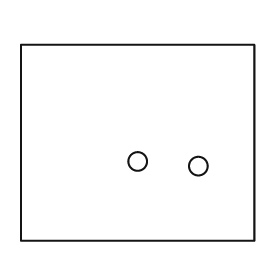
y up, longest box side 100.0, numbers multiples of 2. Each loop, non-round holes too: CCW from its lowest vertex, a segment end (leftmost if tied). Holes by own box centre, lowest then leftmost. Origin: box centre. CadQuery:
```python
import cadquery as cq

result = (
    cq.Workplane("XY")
    .moveTo(-50.0, -42.0)
    .lineTo(50.0, -42.0)
    .lineTo(50.0, 42.0)
    .lineTo(-50.0, 42.0)
    .close()
    .moveTo(26.0, -10.0)
    .circle(4.0)
    .moveTo(0.0, -8.0)
    .circle(4.0)
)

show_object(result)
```